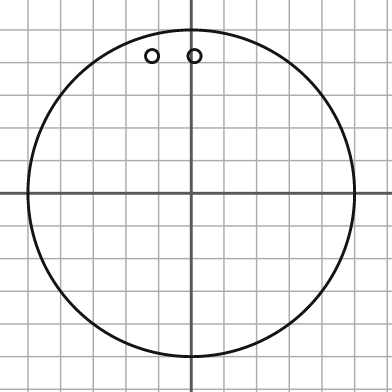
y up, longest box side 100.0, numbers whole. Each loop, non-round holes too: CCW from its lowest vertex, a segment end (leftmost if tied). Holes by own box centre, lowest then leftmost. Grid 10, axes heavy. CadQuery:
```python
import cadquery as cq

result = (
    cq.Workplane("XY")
    .moveTo(0.0, 0.0)
    .circle(50.0)
    .moveTo(-12.0, 42.0)
    .circle(2.0)
    .moveTo(1.0, 42.0)
    .circle(2.0)
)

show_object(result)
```